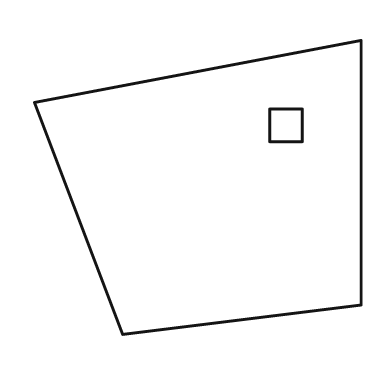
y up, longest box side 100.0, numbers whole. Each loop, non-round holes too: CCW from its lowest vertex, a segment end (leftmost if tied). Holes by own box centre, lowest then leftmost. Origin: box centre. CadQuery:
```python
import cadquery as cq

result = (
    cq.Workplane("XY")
    .moveTo(-23.0, -45.0)
    .lineTo(50.0, -36.0)
    .lineTo(50.0, 45.0)
    .lineTo(-50.0, 26.0)
    .close()
    .moveTo(22.0, 14.0)
    .lineTo(32.0, 14.0)
    .lineTo(32.0, 24.0)
    .lineTo(22.0, 24.0)
    .close()
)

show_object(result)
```